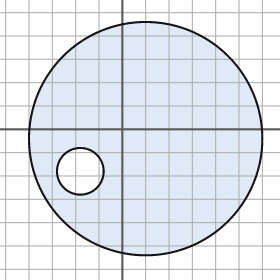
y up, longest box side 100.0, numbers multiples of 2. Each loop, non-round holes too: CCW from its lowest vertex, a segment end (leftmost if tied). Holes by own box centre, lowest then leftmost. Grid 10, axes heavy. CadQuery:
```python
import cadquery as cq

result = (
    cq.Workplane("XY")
    .moveTo(10.0, -4.0)
    .circle(50.0)
    .moveTo(-18.0, -18.0)
    .circle(10.0)
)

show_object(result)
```